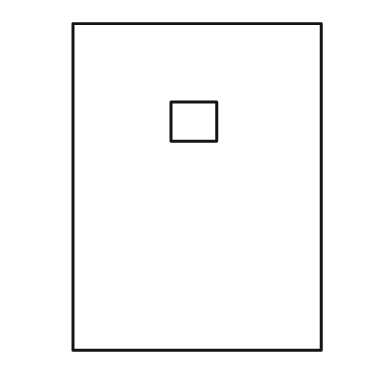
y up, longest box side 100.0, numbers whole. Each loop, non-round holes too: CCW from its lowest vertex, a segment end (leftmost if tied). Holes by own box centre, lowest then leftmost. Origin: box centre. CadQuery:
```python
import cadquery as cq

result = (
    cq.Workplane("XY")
    .moveTo(-38.0, -50.0)
    .lineTo(38.0, -50.0)
    .lineTo(38.0, 50.0)
    .lineTo(-38.0, 50.0)
    .close()
    .moveTo(-8.0, 14.0)
    .lineTo(6.0, 14.0)
    .lineTo(6.0, 26.0)
    .lineTo(-8.0, 26.0)
    .close()
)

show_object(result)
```